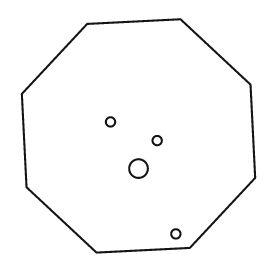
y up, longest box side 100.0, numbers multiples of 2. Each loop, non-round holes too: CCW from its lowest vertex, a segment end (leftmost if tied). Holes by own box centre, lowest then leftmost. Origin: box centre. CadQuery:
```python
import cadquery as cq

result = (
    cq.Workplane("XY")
    .moveTo(-18.0, -50.0)
    .lineTo(22.0, -48.0)
    .lineTo(50.0, -18.0)
    .lineTo(48.0, 22.0)
    .lineTo(18.0, 50.0)
    .lineTo(-22.0, 48.0)
    .lineTo(-50.0, 18.0)
    .lineTo(-48.0, -22.0)
    .close()
    .moveTo(16.0, -42.0)
    .circle(2.0)
    .moveTo(0.0, -14.0)
    .circle(4.0)
    .moveTo(8.0, -2.0)
    .circle(2.0)
    .moveTo(-12.0, 6.0)
    .circle(2.0)
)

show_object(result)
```